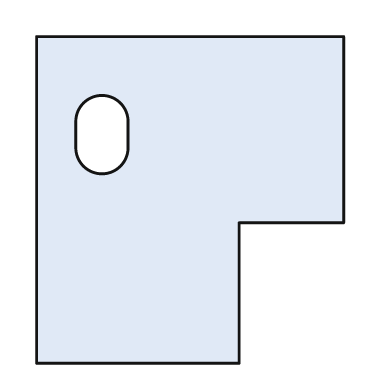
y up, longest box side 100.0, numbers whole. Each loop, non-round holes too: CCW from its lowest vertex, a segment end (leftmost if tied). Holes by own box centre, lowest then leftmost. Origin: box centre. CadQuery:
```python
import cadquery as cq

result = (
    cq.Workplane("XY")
    .moveTo(-47.0, -50.0)
    .lineTo(15.0, -50.0)
    .lineTo(15.0, -7.0)
    .lineTo(47.0, -7.0)
    .lineTo(47.0, 50.0)
    .lineTo(-47.0, 50.0)
    .close()
    .moveTo(-35.0, 16.0)
    .threePointArc((-27.0, 8.0), (-19.0, 16.0))
    .lineTo(-19.0, 24.0)
    .threePointArc((-27.0, 32.0), (-35.0, 24.0))
    .close()
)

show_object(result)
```